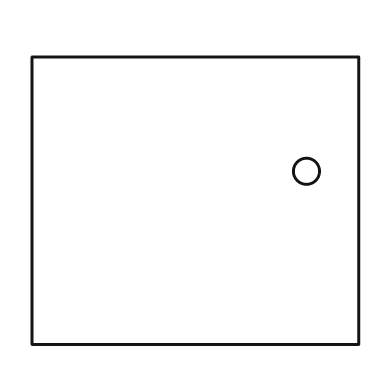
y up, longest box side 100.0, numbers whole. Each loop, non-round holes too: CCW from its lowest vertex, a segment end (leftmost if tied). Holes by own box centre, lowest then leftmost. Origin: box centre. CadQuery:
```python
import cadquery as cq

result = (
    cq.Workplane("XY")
    .moveTo(-50.0, -44.0)
    .lineTo(50.0, -44.0)
    .lineTo(50.0, 44.0)
    .lineTo(-50.0, 44.0)
    .close()
    .moveTo(34.0, 9.0)
    .circle(4.0)
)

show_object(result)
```